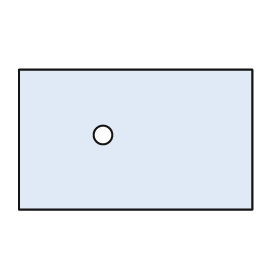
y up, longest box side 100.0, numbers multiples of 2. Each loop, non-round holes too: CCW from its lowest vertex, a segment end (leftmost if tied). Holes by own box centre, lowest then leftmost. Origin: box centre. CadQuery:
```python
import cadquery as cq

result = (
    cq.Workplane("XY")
    .moveTo(-50.0, -30.0)
    .lineTo(50.0, -30.0)
    .lineTo(50.0, 30.0)
    .lineTo(-50.0, 30.0)
    .close()
    .moveTo(-14.0, 2.0)
    .circle(4.0)
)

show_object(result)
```